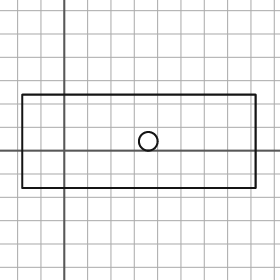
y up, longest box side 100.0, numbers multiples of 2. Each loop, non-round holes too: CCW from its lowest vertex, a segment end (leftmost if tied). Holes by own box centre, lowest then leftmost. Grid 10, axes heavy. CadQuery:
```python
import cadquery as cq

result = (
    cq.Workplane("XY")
    .moveTo(-18.0, -16.0)
    .lineTo(82.0, -16.0)
    .lineTo(82.0, 24.0)
    .lineTo(-18.0, 24.0)
    .close()
    .moveTo(36.0, 4.0)
    .circle(4.0)
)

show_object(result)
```